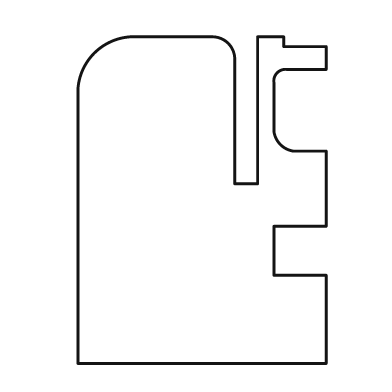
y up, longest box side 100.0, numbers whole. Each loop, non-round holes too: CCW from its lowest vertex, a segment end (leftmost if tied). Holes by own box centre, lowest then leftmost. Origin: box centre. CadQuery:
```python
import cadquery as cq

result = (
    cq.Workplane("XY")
    .moveTo(-38.0, -50.0)
    .lineTo(38.0, -50.0)
    .lineTo(38.0, -23.0)
    .lineTo(22.0, -23.0)
    .lineTo(22.0, -8.0)
    .lineTo(38.0, -8.0)
    .lineTo(38.0, 15.0)
    .lineTo(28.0, 15.0)
    .threePointArc((24.0, 17.0), (22.0, 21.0))
    .lineTo(22.0, 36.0)
    .threePointArc((23.0, 39.0), (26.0, 40.0))
    .lineTo(38.0, 40.0)
    .lineTo(38.0, 47.0)
    .lineTo(25.0, 47.0)
    .lineTo(25.0, 50.0)
    .lineTo(17.0, 50.0)
    .lineTo(17.0, 5.0)
    .lineTo(10.0, 5.0)
    .lineTo(10.0, 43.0)
    .threePointArc((8.0, 48.0), (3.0, 50.0))
    .lineTo(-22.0, 50.0)
    .threePointArc((-33.0, 45.0), (-38.0, 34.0))
    .close()
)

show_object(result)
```